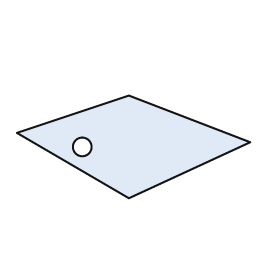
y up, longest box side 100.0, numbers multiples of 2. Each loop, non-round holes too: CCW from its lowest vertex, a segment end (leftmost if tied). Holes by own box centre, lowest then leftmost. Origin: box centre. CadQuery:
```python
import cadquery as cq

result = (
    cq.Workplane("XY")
    .moveTo(-2.0, -22.0)
    .lineTo(50.0, 2.0)
    .lineTo(-2.0, 22.0)
    .lineTo(-50.0, 6.0)
    .close()
    .moveTo(-22.0, 0.0)
    .circle(4.0)
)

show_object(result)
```